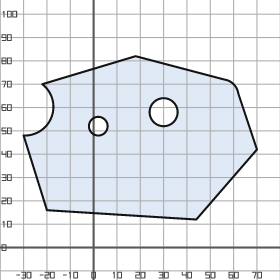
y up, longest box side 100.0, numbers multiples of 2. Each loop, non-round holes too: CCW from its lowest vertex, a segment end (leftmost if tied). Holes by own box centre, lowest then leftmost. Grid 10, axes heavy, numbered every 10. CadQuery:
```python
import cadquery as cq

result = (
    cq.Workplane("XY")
    .moveTo(44.0, 12.0)
    .lineTo(70.0, 42.0)
    .lineTo(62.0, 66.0)
    .threePointArc((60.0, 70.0), (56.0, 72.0))
    .lineTo(18.0, 82.0)
    .lineTo(-22.0, 70.0)
    .threePointArc((-18.0, 56.0), (-30.0, 48.0))
    .lineTo(-20.0, 16.0)
    .close()
    .moveTo(2.0, 52.0)
    .circle(4.0)
    .moveTo(30.0, 58.0)
    .circle(6.0)
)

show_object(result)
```